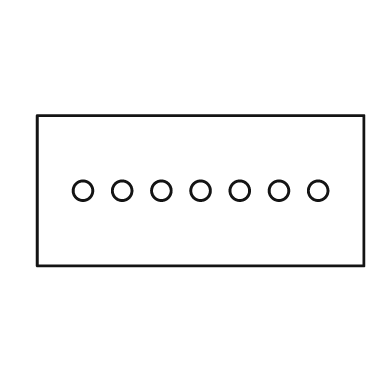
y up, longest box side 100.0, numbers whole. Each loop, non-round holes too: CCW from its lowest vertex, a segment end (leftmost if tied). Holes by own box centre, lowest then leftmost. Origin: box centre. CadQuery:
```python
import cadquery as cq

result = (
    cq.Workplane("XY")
    .moveTo(-50.0, -23.0)
    .lineTo(50.0, -23.0)
    .lineTo(50.0, 23.0)
    .lineTo(-50.0, 23.0)
    .close()
    .moveTo(-36.0, 0.0)
    .circle(3.0)
    .moveTo(-24.0, 0.0)
    .circle(3.0)
    .moveTo(-12.0, 0.0)
    .circle(3.0)
    .moveTo(0.0, 0.0)
    .circle(3.0)
    .moveTo(12.0, 0.0)
    .circle(3.0)
    .moveTo(24.0, 0.0)
    .circle(3.0)
    .moveTo(36.0, 0.0)
    .circle(3.0)
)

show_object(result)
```